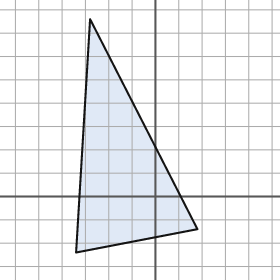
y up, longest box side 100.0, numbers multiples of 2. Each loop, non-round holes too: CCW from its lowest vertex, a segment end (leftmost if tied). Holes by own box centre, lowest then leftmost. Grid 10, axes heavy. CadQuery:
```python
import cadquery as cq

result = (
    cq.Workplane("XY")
    .moveTo(-34.0, -24.0)
    .lineTo(18.0, -14.0)
    .lineTo(-28.0, 76.0)
    .close()
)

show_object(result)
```